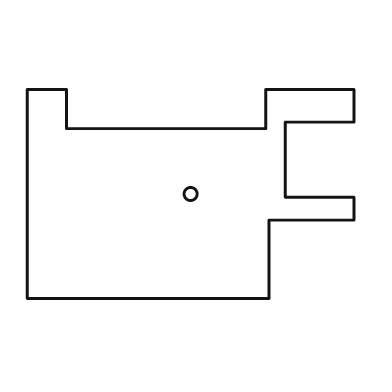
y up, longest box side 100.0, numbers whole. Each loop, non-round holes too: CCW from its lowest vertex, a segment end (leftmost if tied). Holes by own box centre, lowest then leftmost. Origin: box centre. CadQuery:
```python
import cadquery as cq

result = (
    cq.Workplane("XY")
    .moveTo(-50.0, -32.0)
    .lineTo(24.0, -32.0)
    .lineTo(24.0, -8.0)
    .lineTo(50.0, -8.0)
    .lineTo(50.0, -1.0)
    .lineTo(29.0, -1.0)
    .lineTo(29.0, 22.0)
    .lineTo(50.0, 22.0)
    .lineTo(50.0, 32.0)
    .lineTo(23.0, 32.0)
    .lineTo(23.0, 20.0)
    .lineTo(-38.0, 20.0)
    .lineTo(-38.0, 32.0)
    .lineTo(-50.0, 32.0)
    .close()
    .moveTo(0.0, 0.0)
    .circle(2.0)
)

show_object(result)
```